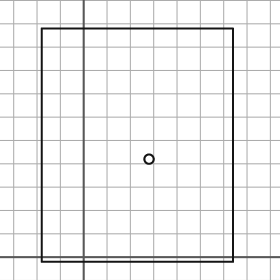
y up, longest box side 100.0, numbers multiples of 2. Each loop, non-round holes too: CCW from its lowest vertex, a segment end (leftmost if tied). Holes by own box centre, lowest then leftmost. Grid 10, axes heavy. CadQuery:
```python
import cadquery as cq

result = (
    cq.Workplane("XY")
    .moveTo(-18.0, -2.0)
    .lineTo(64.0, -2.0)
    .lineTo(64.0, 98.0)
    .lineTo(-18.0, 98.0)
    .close()
    .moveTo(28.0, 42.0)
    .circle(2.0)
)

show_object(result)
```